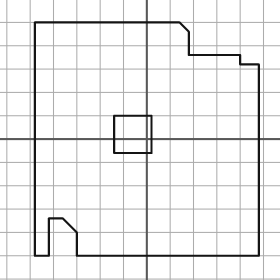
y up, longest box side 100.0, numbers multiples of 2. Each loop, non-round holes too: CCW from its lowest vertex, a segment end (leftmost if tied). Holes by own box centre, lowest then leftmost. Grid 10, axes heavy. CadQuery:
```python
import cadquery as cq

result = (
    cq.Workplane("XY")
    .moveTo(-48.0, -50.0)
    .lineTo(-42.0, -50.0)
    .lineTo(-42.0, -34.0)
    .lineTo(-36.0, -34.0)
    .lineTo(-30.0, -40.0)
    .lineTo(-30.0, -50.0)
    .lineTo(48.0, -50.0)
    .lineTo(48.0, 32.0)
    .lineTo(40.0, 32.0)
    .lineTo(40.0, 36.0)
    .lineTo(18.0, 36.0)
    .lineTo(18.0, 46.0)
    .lineTo(14.0, 50.0)
    .lineTo(-48.0, 50.0)
    .close()
    .moveTo(-14.0, -6.0)
    .lineTo(2.0, -6.0)
    .lineTo(2.0, 10.0)
    .lineTo(-14.0, 10.0)
    .close()
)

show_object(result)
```